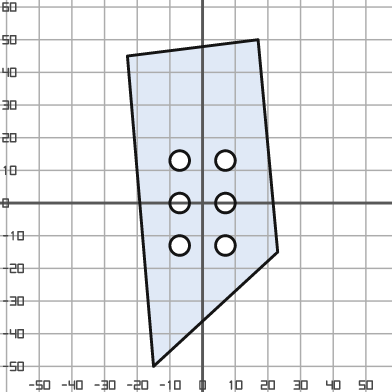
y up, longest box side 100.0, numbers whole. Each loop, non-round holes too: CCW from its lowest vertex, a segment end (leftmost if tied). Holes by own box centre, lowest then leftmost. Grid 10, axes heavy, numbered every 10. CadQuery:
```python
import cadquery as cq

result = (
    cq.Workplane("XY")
    .moveTo(-15.0, -50.0)
    .lineTo(23.0, -15.0)
    .lineTo(17.0, 50.0)
    .lineTo(-23.0, 45.0)
    .close()
    .moveTo(-7.0, -13.0)
    .circle(3.0)
    .moveTo(7.0, -13.0)
    .circle(3.0)
    .moveTo(-7.0, 0.0)
    .circle(3.0)
    .moveTo(7.0, 0.0)
    .circle(3.0)
    .moveTo(-7.0, 13.0)
    .circle(3.0)
    .moveTo(7.0, 13.0)
    .circle(3.0)
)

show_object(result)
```